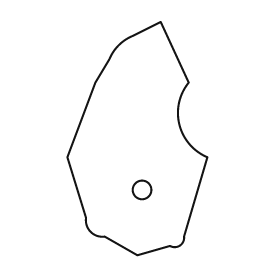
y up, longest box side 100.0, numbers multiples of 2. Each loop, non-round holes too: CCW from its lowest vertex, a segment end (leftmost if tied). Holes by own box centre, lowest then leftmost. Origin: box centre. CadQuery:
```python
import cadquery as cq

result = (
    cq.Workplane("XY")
    .moveTo(0.0, -50.0)
    .lineTo(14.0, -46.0)
    .threePointArc((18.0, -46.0), (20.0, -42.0))
    .lineTo(30.0, -8.0)
    .threePointArc((18.0, 6.0), (22.0, 24.0))
    .lineTo(10.0, 50.0)
    .lineTo(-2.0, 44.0)
    .threePointArc((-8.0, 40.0), (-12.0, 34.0))
    .lineTo(-18.0, 24.0)
    .lineTo(-30.0, -8.0)
    .lineTo(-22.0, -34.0)
    .threePointArc((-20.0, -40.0), (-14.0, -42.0))
    .close()
    .moveTo(2.0, -22.0)
    .circle(4.0)
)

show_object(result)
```